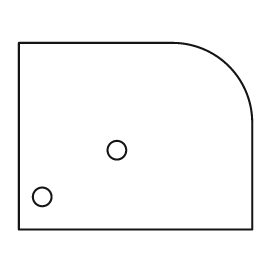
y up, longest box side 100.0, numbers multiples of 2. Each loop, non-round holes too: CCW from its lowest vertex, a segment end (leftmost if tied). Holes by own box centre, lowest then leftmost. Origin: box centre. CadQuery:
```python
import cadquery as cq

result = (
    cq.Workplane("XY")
    .moveTo(-50.0, -40.0)
    .lineTo(50.0, -40.0)
    .lineTo(50.0, 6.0)
    .threePointArc((40.0, 30.0), (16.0, 40.0))
    .lineTo(-50.0, 40.0)
    .close()
    .moveTo(-40.0, -26.0)
    .circle(4.0)
    .moveTo(-8.0, -6.0)
    .circle(4.0)
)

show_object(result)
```